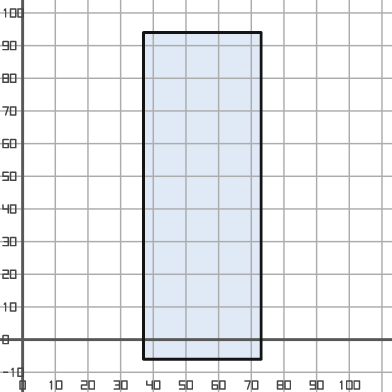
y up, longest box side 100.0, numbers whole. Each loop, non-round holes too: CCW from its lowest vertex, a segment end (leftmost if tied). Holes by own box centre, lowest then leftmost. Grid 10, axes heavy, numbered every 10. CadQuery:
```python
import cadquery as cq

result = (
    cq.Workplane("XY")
    .moveTo(37.0, -6.0)
    .lineTo(73.0, -6.0)
    .lineTo(73.0, 94.0)
    .lineTo(37.0, 94.0)
    .close()
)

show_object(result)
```